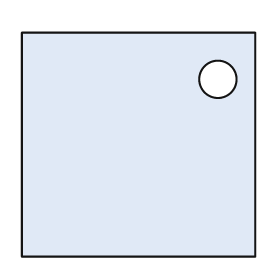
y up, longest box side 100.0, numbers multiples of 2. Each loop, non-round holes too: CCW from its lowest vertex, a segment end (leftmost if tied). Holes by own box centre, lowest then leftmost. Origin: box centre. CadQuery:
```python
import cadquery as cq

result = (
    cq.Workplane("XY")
    .moveTo(-50.0, -48.0)
    .lineTo(50.0, -48.0)
    .lineTo(50.0, 48.0)
    .lineTo(-50.0, 48.0)
    .close()
    .moveTo(34.0, 28.0)
    .circle(8.0)
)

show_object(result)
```